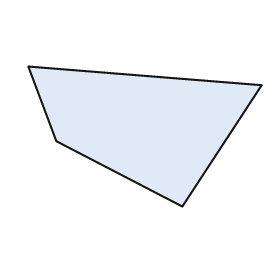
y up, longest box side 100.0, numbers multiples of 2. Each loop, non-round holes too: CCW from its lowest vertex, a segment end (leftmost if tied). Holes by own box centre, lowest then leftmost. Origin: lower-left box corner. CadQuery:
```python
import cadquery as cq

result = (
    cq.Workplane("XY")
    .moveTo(66.0, 0.0)
    .lineTo(100.0, 52.0)
    .lineTo(0.0, 60.0)
    .lineTo(12.0, 28.0)
    .close()
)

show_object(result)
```